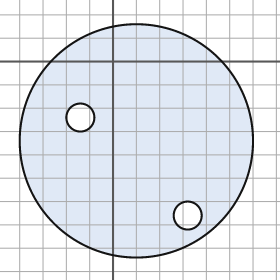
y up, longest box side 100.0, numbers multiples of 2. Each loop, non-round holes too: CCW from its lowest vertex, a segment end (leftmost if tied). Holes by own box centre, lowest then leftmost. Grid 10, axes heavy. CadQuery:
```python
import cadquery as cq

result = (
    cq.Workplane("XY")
    .moveTo(10.0, -34.0)
    .circle(50.0)
    .moveTo(32.0, -66.0)
    .circle(6.0)
    .moveTo(-14.0, -24.0)
    .circle(6.0)
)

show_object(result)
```